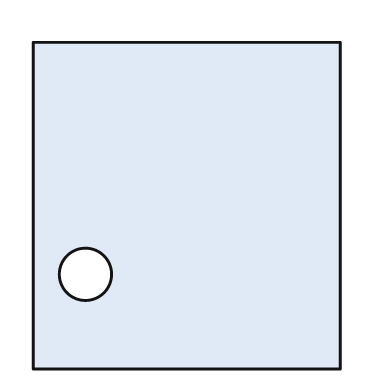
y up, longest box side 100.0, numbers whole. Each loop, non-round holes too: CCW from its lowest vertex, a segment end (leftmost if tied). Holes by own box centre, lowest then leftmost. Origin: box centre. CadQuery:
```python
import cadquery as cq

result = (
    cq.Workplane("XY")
    .moveTo(-47.0, -50.0)
    .lineTo(47.0, -50.0)
    .lineTo(47.0, 50.0)
    .lineTo(-47.0, 50.0)
    .close()
    .moveTo(-31.0, -21.0)
    .circle(8.0)
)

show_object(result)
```